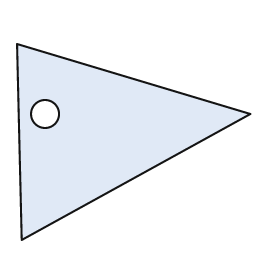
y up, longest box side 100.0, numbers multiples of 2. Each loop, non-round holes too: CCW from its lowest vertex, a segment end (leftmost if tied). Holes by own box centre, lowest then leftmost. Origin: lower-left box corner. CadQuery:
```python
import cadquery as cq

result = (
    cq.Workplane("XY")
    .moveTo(2.0, 0.0)
    .lineTo(100.0, 54.0)
    .lineTo(0.0, 84.0)
    .close()
    .moveTo(12.0, 54.0)
    .circle(6.0)
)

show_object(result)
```